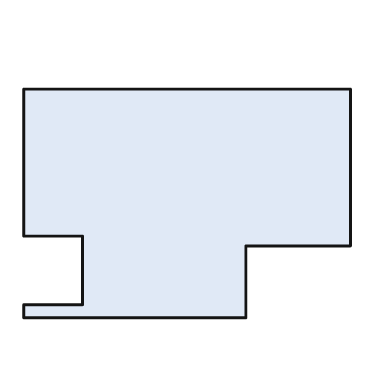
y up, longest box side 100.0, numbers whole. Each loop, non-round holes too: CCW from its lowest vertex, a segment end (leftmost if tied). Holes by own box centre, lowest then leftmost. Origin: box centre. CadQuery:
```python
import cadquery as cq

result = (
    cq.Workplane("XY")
    .moveTo(-50.0, -35.0)
    .lineTo(18.0, -35.0)
    .lineTo(18.0, -13.0)
    .lineTo(50.0, -13.0)
    .lineTo(50.0, 35.0)
    .lineTo(-50.0, 35.0)
    .lineTo(-50.0, -10.0)
    .lineTo(-32.0, -10.0)
    .lineTo(-32.0, -31.0)
    .lineTo(-50.0, -31.0)
    .close()
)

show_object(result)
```